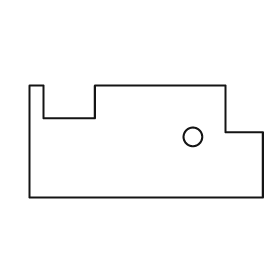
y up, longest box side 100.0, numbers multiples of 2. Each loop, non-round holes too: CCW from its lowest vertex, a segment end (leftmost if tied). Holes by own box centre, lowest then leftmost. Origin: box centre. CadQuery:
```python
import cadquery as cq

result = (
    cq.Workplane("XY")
    .moveTo(-50.0, -24.0)
    .lineTo(50.0, -24.0)
    .lineTo(50.0, 4.0)
    .lineTo(34.0, 4.0)
    .lineTo(34.0, 24.0)
    .lineTo(-22.0, 24.0)
    .lineTo(-22.0, 10.0)
    .lineTo(-44.0, 10.0)
    .lineTo(-44.0, 24.0)
    .lineTo(-50.0, 24.0)
    .close()
    .moveTo(20.0, 2.0)
    .circle(4.0)
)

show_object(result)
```